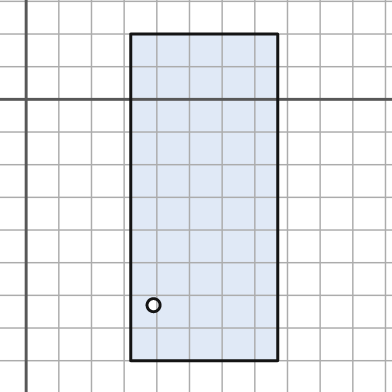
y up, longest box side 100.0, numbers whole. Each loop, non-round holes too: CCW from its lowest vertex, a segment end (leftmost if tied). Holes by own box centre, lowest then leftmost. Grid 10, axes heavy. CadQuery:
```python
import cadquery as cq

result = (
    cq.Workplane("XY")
    .moveTo(32.0, -80.0)
    .lineTo(77.0, -80.0)
    .lineTo(77.0, 20.0)
    .lineTo(32.0, 20.0)
    .close()
    .moveTo(39.0, -63.0)
    .circle(2.0)
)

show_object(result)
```